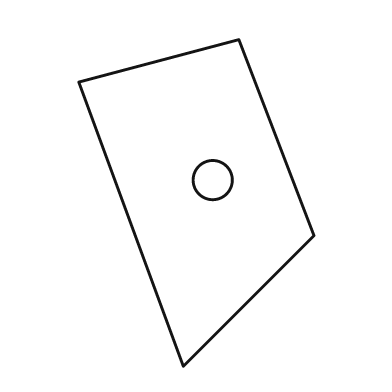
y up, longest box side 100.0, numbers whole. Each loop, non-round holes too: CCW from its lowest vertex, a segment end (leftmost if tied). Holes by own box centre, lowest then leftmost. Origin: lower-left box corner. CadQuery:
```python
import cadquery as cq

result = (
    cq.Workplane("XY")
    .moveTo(32.0, 0.0)
    .lineTo(72.0, 40.0)
    .lineTo(49.0, 100.0)
    .lineTo(0.0, 87.0)
    .close()
    .moveTo(41.0, 57.0)
    .circle(6.0)
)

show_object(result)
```